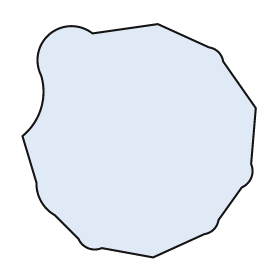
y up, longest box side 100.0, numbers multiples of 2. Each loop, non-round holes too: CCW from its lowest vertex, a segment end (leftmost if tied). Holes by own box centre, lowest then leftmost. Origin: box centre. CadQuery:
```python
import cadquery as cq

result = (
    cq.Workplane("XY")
    .moveTo(6.0, -50.0)
    .lineTo(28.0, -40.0)
    .threePointArc((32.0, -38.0), (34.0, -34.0))
    .lineTo(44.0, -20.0)
    .threePointArc((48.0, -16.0), (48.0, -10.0))
    .lineTo(50.0, 14.0)
    .lineTo(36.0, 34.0)
    .threePointArc((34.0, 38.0), (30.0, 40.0))
    .lineTo(8.0, 50.0)
    .lineTo(-20.0, 46.0)
    .threePointArc((-38.0, 46.0), (-42.0, 28.0))
    .threePointArc((-42.0, 14.0), (-50.0, 2.0))
    .lineTo(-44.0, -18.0)
    .threePointArc((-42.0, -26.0), (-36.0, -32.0))
    .lineTo(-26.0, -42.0)
    .threePointArc((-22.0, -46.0), (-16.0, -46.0))
    .close()
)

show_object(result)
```